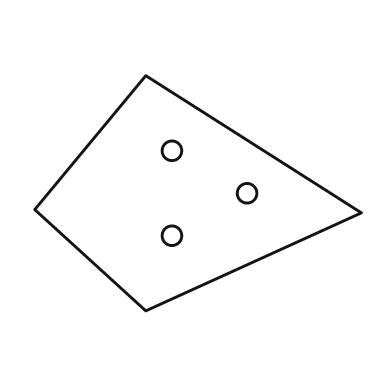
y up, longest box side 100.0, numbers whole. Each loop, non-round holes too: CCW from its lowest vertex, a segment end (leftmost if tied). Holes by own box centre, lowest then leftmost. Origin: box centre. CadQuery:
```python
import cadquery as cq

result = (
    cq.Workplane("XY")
    .moveTo(-16.0, -36.0)
    .lineTo(50.0, -6.0)
    .lineTo(-16.0, 36.0)
    .lineTo(-50.0, -5.0)
    .close()
    .moveTo(-8.0, -13.0)
    .circle(3.0)
    .moveTo(15.0, 0.0)
    .circle(3.0)
    .moveTo(-8.0, 13.0)
    .circle(3.0)
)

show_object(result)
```